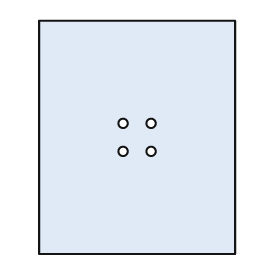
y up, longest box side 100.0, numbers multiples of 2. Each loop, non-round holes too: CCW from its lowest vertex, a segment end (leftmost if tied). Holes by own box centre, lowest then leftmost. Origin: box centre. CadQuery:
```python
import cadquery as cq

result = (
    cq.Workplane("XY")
    .moveTo(-42.0, -50.0)
    .lineTo(42.0, -50.0)
    .lineTo(42.0, 50.0)
    .lineTo(-42.0, 50.0)
    .close()
    .moveTo(-6.0, -6.0)
    .circle(2.0)
    .moveTo(6.0, -6.0)
    .circle(2.0)
    .moveTo(-6.0, 6.0)
    .circle(2.0)
    .moveTo(6.0, 6.0)
    .circle(2.0)
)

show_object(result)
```